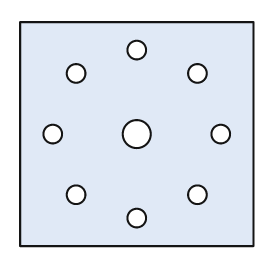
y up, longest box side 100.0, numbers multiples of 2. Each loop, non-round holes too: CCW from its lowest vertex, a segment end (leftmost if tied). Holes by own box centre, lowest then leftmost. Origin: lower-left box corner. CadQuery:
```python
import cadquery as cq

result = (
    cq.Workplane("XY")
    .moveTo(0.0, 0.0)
    .lineTo(100.0, 0.0)
    .lineTo(100.0, 96.0)
    .lineTo(0.0, 96.0)
    .close()
    .moveTo(50.0, 12.0)
    .circle(4.0)
    .moveTo(24.0, 22.0)
    .circle(4.0)
    .moveTo(76.0, 22.0)
    .circle(4.0)
    .moveTo(14.0, 48.0)
    .circle(4.0)
    .moveTo(50.0, 48.0)
    .circle(6.0)
    .moveTo(86.0, 48.0)
    .circle(4.0)
    .moveTo(24.0, 74.0)
    .circle(4.0)
    .moveTo(76.0, 74.0)
    .circle(4.0)
    .moveTo(50.0, 84.0)
    .circle(4.0)
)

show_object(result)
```